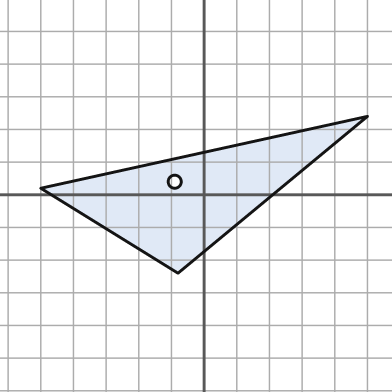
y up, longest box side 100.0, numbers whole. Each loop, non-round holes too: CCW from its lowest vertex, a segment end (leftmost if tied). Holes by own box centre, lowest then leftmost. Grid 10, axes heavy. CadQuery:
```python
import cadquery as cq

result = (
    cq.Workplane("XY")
    .moveTo(-8.0, -24.0)
    .lineTo(50.0, 24.0)
    .lineTo(-50.0, 2.0)
    .close()
    .moveTo(-9.0, 4.0)
    .circle(2.0)
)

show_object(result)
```